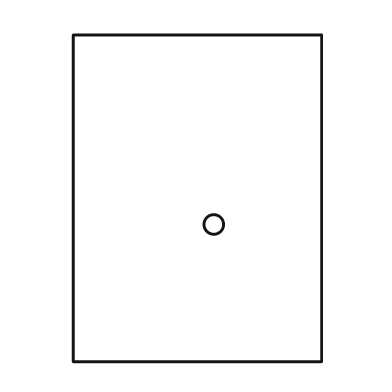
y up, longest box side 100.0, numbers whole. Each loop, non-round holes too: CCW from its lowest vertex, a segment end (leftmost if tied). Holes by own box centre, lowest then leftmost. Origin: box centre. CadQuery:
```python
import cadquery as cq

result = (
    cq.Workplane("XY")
    .moveTo(-38.0, -50.0)
    .lineTo(38.0, -50.0)
    .lineTo(38.0, 50.0)
    .lineTo(-38.0, 50.0)
    .close()
    .moveTo(5.0, -8.0)
    .circle(3.0)
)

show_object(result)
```